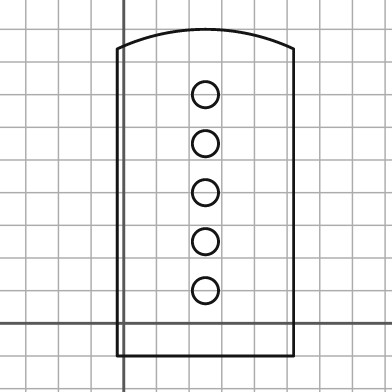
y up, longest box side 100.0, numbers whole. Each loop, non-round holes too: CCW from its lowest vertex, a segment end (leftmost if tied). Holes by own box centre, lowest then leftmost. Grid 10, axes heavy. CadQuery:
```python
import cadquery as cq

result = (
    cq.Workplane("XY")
    .moveTo(-2.0, -10.0)
    .lineTo(52.0, -10.0)
    .lineTo(52.0, 84.0)
    .threePointArc((25.0, 90.0), (-2.0, 84.0))
    .close()
    .moveTo(25.0, 10.0)
    .circle(4.0)
    .moveTo(25.0, 25.0)
    .circle(4.0)
    .moveTo(25.0, 40.0)
    .circle(4.0)
    .moveTo(25.0, 55.0)
    .circle(4.0)
    .moveTo(25.0, 70.0)
    .circle(4.0)
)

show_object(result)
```